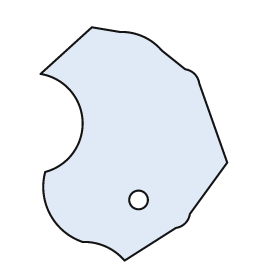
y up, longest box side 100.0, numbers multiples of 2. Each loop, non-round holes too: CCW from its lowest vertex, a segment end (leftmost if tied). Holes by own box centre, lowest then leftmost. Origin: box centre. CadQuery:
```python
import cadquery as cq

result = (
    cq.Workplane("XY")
    .moveTo(-4.0, -50.0)
    .lineTo(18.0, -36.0)
    .threePointArc((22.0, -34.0), (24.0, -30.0))
    .lineTo(40.0, -8.0)
    .lineTo(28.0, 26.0)
    .threePointArc((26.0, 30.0), (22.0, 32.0))
    .lineTo(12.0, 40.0)
    .threePointArc((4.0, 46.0), (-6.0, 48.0))
    .lineTo(-18.0, 50.0)
    .lineTo(-40.0, 30.0)
    .threePointArc((-22.0, 10.0), (-38.0, -12.0))
    .threePointArc((-36.0, -30.0), (-22.0, -42.0))
    .threePointArc((-12.0, -44.0), (-4.0, -50.0))
    .close()
    .moveTo(2.0, -24.0)
    .circle(4.0)
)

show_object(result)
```